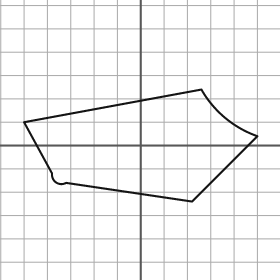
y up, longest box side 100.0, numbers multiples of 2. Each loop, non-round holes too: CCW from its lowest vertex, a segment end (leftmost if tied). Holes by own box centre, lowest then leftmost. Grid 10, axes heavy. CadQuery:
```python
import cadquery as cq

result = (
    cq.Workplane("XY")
    .moveTo(22.0, -24.0)
    .lineTo(50.0, 4.0)
    .threePointArc((36.0, 12.0), (26.0, 24.0))
    .lineTo(-50.0, 10.0)
    .lineTo(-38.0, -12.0)
    .threePointArc((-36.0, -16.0), (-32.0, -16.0))
    .close()
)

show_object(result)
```